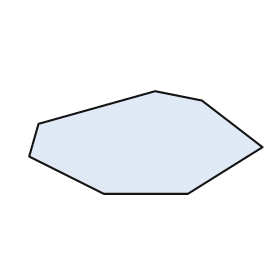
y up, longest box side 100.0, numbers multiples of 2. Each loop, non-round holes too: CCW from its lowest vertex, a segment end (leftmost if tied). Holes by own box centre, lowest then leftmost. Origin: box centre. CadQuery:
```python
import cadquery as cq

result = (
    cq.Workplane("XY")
    .moveTo(-18.0, -22.0)
    .lineTo(18.0, -22.0)
    .lineTo(50.0, -2.0)
    .lineTo(24.0, 18.0)
    .lineTo(4.0, 22.0)
    .lineTo(-46.0, 8.0)
    .lineTo(-50.0, -6.0)
    .close()
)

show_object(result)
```